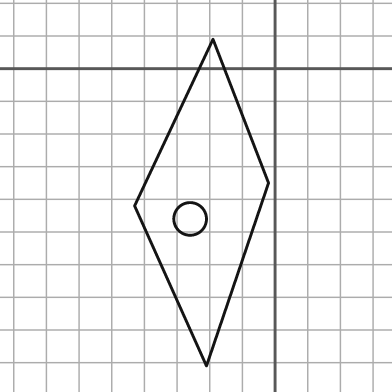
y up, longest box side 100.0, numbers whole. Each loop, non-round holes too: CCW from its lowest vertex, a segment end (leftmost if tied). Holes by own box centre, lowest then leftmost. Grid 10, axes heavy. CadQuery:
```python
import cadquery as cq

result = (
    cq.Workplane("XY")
    .moveTo(-21.0, -91.0)
    .lineTo(-2.0, -35.0)
    .lineTo(-19.0, 9.0)
    .lineTo(-43.0, -42.0)
    .close()
    .moveTo(-26.0, -46.0)
    .circle(5.0)
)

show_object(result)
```